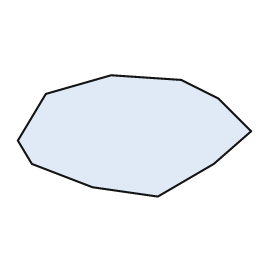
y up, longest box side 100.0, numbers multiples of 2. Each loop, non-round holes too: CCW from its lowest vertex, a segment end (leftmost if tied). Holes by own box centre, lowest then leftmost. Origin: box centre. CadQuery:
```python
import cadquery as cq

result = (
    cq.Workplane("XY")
    .moveTo(10.0, -26.0)
    .lineTo(34.0, -12.0)
    .lineTo(50.0, 2.0)
    .lineTo(36.0, 16.0)
    .lineTo(20.0, 24.0)
    .lineTo(-10.0, 26.0)
    .lineTo(-38.0, 18.0)
    .lineTo(-50.0, -2.0)
    .lineTo(-44.0, -12.0)
    .lineTo(-18.0, -22.0)
    .close()
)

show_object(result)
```